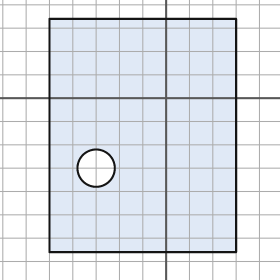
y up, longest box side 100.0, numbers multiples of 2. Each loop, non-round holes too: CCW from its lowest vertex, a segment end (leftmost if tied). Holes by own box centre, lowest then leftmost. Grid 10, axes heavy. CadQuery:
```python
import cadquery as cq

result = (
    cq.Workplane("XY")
    .moveTo(-50.0, -66.0)
    .lineTo(30.0, -66.0)
    .lineTo(30.0, 34.0)
    .lineTo(-50.0, 34.0)
    .close()
    .moveTo(-30.0, -30.0)
    .circle(8.0)
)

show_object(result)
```